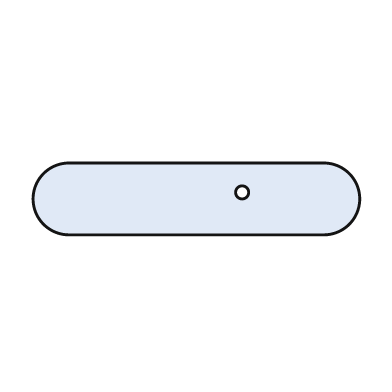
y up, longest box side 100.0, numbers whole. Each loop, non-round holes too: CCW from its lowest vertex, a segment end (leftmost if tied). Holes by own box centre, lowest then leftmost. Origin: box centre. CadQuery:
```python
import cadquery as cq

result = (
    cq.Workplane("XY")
    .moveTo(-39.0, -11.0)
    .lineTo(39.0, -11.0)
    .threePointArc((50.0, 0.0), (39.0, 11.0))
    .lineTo(-39.0, 11.0)
    .threePointArc((-50.0, 0.0), (-39.0, -11.0))
    .close()
    .moveTo(14.0, 2.0)
    .circle(2.0)
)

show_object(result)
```